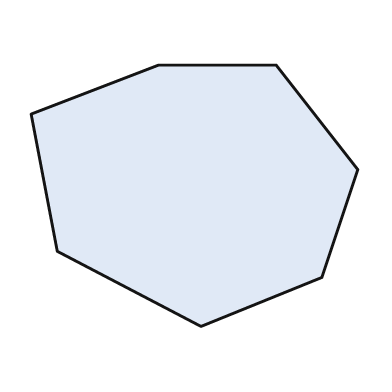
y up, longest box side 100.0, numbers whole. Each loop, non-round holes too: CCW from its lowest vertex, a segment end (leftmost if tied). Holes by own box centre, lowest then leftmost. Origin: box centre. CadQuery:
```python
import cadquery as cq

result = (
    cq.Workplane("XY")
    .moveTo(2.0, -40.0)
    .lineTo(39.0, -25.0)
    .lineTo(50.0, 8.0)
    .lineTo(25.0, 40.0)
    .lineTo(-11.0, 40.0)
    .lineTo(-50.0, 25.0)
    .lineTo(-42.0, -17.0)
    .close()
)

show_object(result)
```